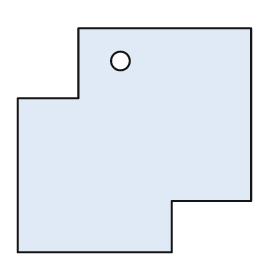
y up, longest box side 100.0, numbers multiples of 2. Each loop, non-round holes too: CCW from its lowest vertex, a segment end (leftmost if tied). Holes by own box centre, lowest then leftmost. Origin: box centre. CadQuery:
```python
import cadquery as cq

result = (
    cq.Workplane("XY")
    .moveTo(-50.0, -48.0)
    .lineTo(16.0, -48.0)
    .lineTo(16.0, -26.0)
    .lineTo(50.0, -26.0)
    .lineTo(50.0, 48.0)
    .lineTo(-24.0, 48.0)
    .lineTo(-24.0, 18.0)
    .lineTo(-50.0, 18.0)
    .close()
    .moveTo(-6.0, 34.0)
    .circle(4.0)
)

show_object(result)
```